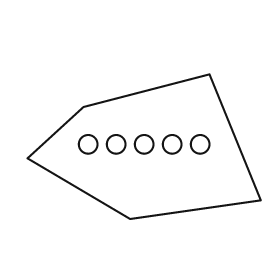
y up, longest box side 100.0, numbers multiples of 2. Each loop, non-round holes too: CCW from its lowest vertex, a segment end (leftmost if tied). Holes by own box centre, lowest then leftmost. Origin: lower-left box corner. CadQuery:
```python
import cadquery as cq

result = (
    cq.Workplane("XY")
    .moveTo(44.0, 0.0)
    .lineTo(100.0, 8.0)
    .lineTo(78.0, 62.0)
    .lineTo(24.0, 48.0)
    .lineTo(0.0, 26.0)
    .close()
    .moveTo(26.0, 32.0)
    .circle(4.0)
    .moveTo(38.0, 32.0)
    .circle(4.0)
    .moveTo(50.0, 32.0)
    .circle(4.0)
    .moveTo(62.0, 32.0)
    .circle(4.0)
    .moveTo(74.0, 32.0)
    .circle(4.0)
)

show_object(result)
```